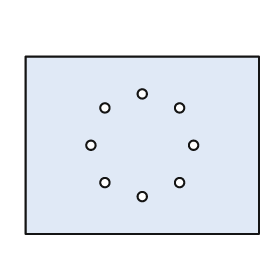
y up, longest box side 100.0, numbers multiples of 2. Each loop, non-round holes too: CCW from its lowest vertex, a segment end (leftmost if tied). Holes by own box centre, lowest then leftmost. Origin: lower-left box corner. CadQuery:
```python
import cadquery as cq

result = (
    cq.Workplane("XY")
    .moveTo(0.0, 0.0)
    .lineTo(100.0, 0.0)
    .lineTo(100.0, 76.0)
    .lineTo(0.0, 76.0)
    .close()
    .moveTo(50.0, 16.0)
    .circle(2.0)
    .moveTo(34.0, 22.0)
    .circle(2.0)
    .moveTo(66.0, 22.0)
    .circle(2.0)
    .moveTo(28.0, 38.0)
    .circle(2.0)
    .moveTo(72.0, 38.0)
    .circle(2.0)
    .moveTo(34.0, 54.0)
    .circle(2.0)
    .moveTo(66.0, 54.0)
    .circle(2.0)
    .moveTo(50.0, 60.0)
    .circle(2.0)
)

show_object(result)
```